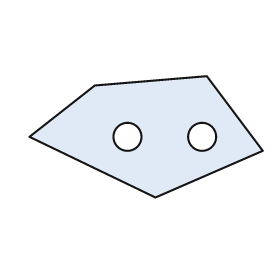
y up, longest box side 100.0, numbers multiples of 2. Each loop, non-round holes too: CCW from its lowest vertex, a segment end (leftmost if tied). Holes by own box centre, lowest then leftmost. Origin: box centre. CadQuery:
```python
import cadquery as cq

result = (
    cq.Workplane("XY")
    .moveTo(4.0, -26.0)
    .lineTo(50.0, -6.0)
    .lineTo(26.0, 26.0)
    .lineTo(-22.0, 22.0)
    .lineTo(-50.0, 0.0)
    .close()
    .moveTo(-8.0, 0.0)
    .circle(6.0)
    .moveTo(24.0, 0.0)
    .circle(6.0)
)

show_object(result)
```